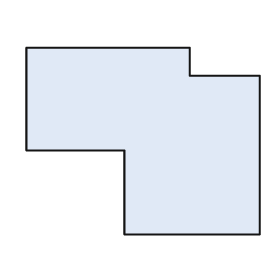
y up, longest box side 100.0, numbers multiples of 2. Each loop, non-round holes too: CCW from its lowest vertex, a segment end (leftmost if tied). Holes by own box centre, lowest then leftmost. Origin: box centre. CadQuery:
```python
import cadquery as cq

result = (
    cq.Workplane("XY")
    .moveTo(-8.0, -40.0)
    .lineTo(50.0, -40.0)
    .lineTo(50.0, 28.0)
    .lineTo(20.0, 28.0)
    .lineTo(20.0, 40.0)
    .lineTo(-50.0, 40.0)
    .lineTo(-50.0, -4.0)
    .lineTo(-8.0, -4.0)
    .close()
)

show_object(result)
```